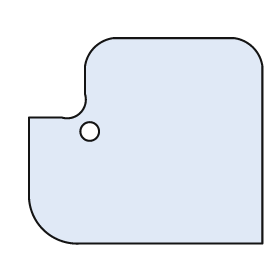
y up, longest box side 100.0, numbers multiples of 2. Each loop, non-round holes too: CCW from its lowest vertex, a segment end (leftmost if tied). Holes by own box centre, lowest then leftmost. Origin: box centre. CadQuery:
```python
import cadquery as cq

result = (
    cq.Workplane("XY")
    .moveTo(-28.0, -44.0)
    .lineTo(50.0, -44.0)
    .lineTo(50.0, 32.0)
    .threePointArc((46.0, 40.0), (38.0, 44.0))
    .lineTo(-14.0, 44.0)
    .threePointArc((-22.0, 40.0), (-26.0, 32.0))
    .lineTo(-26.0, 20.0)
    .threePointArc((-28.0, 12.0), (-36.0, 10.0))
    .lineTo(-50.0, 10.0)
    .lineTo(-50.0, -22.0)
    .threePointArc((-44.0, -38.0), (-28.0, -44.0))
    .close()
    .moveTo(-24.0, 4.0)
    .circle(4.0)
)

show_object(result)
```